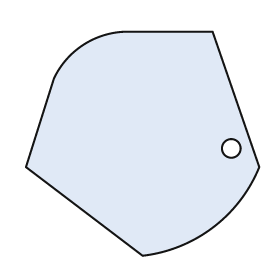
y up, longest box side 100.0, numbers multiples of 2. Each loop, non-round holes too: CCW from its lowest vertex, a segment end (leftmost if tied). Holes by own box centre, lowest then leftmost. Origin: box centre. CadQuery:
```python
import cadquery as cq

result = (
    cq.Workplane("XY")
    .moveTo(0.0, -48.0)
    .threePointArc((30.0, -36.0), (50.0, -10.0))
    .lineTo(30.0, 48.0)
    .lineTo(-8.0, 48.0)
    .threePointArc((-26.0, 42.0), (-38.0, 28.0))
    .lineTo(-50.0, -10.0)
    .close()
    .moveTo(38.0, -2.0)
    .circle(4.0)
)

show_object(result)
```